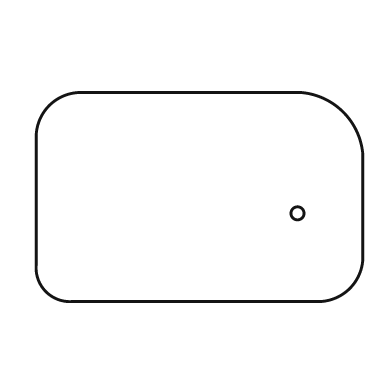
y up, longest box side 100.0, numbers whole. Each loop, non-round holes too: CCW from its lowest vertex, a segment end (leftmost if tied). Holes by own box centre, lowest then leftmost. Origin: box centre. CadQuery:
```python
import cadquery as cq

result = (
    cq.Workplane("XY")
    .moveTo(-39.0, -32.0)
    .lineTo(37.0, -32.0)
    .threePointArc((46.0, -28.0), (50.0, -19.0))
    .lineTo(50.0, 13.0)
    .threePointArc((44.0, 26.0), (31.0, 32.0))
    .lineTo(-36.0, 32.0)
    .threePointArc((-46.0, 28.0), (-50.0, 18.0))
    .lineTo(-50.0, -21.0)
    .threePointArc((-47.0, -29.0), (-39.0, -32.0))
    .close()
    .moveTo(30.0, -5.0)
    .circle(2.0)
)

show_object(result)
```